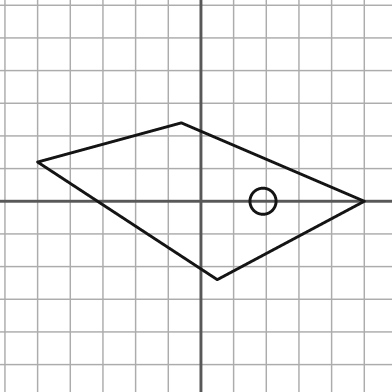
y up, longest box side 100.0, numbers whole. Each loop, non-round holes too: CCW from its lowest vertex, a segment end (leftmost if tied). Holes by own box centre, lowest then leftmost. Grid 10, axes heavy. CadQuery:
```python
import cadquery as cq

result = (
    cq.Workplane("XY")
    .moveTo(5.0, -24.0)
    .lineTo(50.0, 0.0)
    .lineTo(-6.0, 24.0)
    .lineTo(-50.0, 12.0)
    .close()
    .moveTo(19.0, 0.0)
    .circle(4.0)
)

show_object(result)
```